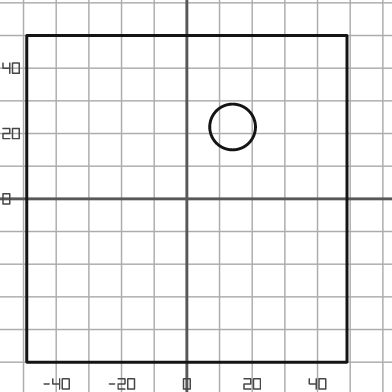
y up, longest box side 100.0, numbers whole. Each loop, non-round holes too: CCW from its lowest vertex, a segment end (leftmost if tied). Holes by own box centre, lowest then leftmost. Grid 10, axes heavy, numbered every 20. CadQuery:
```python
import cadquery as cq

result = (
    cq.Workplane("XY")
    .moveTo(-49.0, -50.0)
    .lineTo(49.0, -50.0)
    .lineTo(49.0, 50.0)
    .lineTo(-49.0, 50.0)
    .close()
    .moveTo(14.0, 22.0)
    .circle(7.0)
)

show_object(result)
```